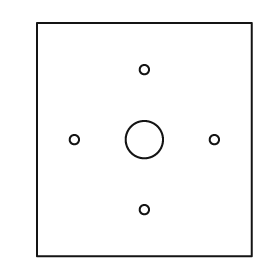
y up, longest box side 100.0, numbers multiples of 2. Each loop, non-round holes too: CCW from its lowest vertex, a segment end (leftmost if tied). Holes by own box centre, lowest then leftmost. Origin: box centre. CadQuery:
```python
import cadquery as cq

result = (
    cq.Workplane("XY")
    .moveTo(-46.0, -50.0)
    .lineTo(46.0, -50.0)
    .lineTo(46.0, 50.0)
    .lineTo(-46.0, 50.0)
    .close()
    .moveTo(0.0, -30.0)
    .circle(2.0)
    .moveTo(-30.0, 0.0)
    .circle(2.0)
    .moveTo(0.0, 0.0)
    .circle(8.0)
    .moveTo(30.0, 0.0)
    .circle(2.0)
    .moveTo(0.0, 30.0)
    .circle(2.0)
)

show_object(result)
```